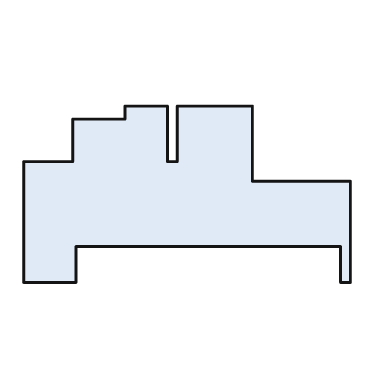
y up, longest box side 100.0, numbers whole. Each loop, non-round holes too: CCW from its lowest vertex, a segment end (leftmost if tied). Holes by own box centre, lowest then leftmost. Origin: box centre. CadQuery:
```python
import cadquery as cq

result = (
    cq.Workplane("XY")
    .moveTo(-50.0, -27.0)
    .lineTo(-34.0, -27.0)
    .lineTo(-34.0, -16.0)
    .lineTo(47.0, -16.0)
    .lineTo(47.0, -27.0)
    .lineTo(50.0, -27.0)
    .lineTo(50.0, 4.0)
    .lineTo(20.0, 4.0)
    .lineTo(20.0, 27.0)
    .lineTo(-3.0, 27.0)
    .lineTo(-3.0, 10.0)
    .lineTo(-6.0, 10.0)
    .lineTo(-6.0, 27.0)
    .lineTo(-19.0, 27.0)
    .lineTo(-19.0, 23.0)
    .lineTo(-35.0, 23.0)
    .lineTo(-35.0, 10.0)
    .lineTo(-50.0, 10.0)
    .close()
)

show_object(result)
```